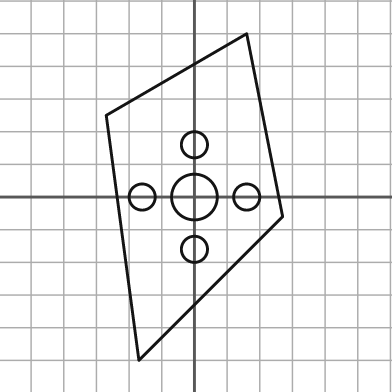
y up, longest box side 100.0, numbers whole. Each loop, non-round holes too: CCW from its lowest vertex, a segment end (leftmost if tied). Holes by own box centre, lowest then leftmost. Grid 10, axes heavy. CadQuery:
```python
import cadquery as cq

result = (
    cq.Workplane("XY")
    .moveTo(-17.0, -50.0)
    .lineTo(27.0, -6.0)
    .lineTo(16.0, 50.0)
    .lineTo(-27.0, 25.0)
    .close()
    .moveTo(0.0, -16.0)
    .circle(4.0)
    .moveTo(-16.0, 0.0)
    .circle(4.0)
    .moveTo(0.0, 0.0)
    .circle(7.0)
    .moveTo(16.0, 0.0)
    .circle(4.0)
    .moveTo(0.0, 16.0)
    .circle(4.0)
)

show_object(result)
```